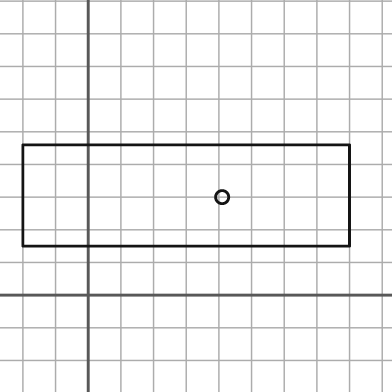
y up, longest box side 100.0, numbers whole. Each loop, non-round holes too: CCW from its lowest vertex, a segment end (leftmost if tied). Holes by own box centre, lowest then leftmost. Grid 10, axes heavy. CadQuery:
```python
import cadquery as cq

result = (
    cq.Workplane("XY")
    .moveTo(-20.0, 15.0)
    .lineTo(80.0, 15.0)
    .lineTo(80.0, 46.0)
    .lineTo(-20.0, 46.0)
    .close()
    .moveTo(41.0, 30.0)
    .circle(2.0)
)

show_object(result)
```